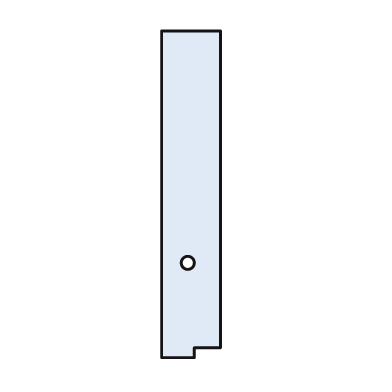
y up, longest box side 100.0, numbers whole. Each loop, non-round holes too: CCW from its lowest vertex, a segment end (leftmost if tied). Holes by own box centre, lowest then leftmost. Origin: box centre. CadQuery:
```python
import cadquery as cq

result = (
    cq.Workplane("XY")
    .moveTo(-9.0, -50.0)
    .lineTo(1.0, -50.0)
    .lineTo(1.0, -47.0)
    .lineTo(9.0, -47.0)
    .lineTo(9.0, 50.0)
    .lineTo(-9.0, 50.0)
    .close()
    .moveTo(-1.0, -21.0)
    .circle(2.0)
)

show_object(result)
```